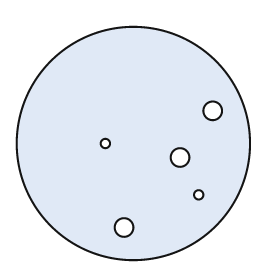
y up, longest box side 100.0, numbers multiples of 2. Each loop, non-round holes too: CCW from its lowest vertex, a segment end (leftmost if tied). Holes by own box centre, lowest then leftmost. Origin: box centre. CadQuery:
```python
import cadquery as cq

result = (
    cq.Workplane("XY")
    .moveTo(0.0, 0.0)
    .circle(50.0)
    .moveTo(-4.0, -36.0)
    .circle(4.0)
    .moveTo(28.0, -22.0)
    .circle(2.0)
    .moveTo(20.0, -6.0)
    .circle(4.0)
    .moveTo(-12.0, 0.0)
    .circle(2.0)
    .moveTo(34.0, 14.0)
    .circle(4.0)
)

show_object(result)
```